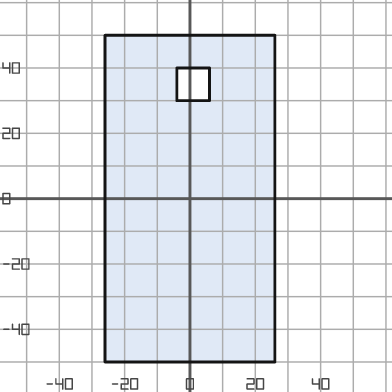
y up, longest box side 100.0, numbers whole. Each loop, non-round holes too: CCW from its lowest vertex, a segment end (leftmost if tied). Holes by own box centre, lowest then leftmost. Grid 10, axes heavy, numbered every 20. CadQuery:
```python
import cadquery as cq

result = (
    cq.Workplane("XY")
    .moveTo(-26.0, -50.0)
    .lineTo(26.0, -50.0)
    .lineTo(26.0, 50.0)
    .lineTo(-26.0, 50.0)
    .close()
    .moveTo(-4.0, 30.0)
    .lineTo(6.0, 30.0)
    .lineTo(6.0, 40.0)
    .lineTo(-4.0, 40.0)
    .close()
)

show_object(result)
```